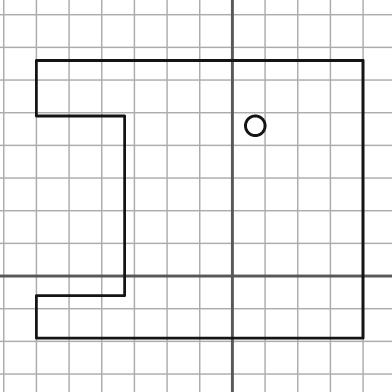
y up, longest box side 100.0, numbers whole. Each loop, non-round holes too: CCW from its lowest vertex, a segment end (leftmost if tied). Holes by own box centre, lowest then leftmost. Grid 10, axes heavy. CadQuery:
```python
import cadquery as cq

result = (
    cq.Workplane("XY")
    .moveTo(-60.0, -19.0)
    .lineTo(40.0, -19.0)
    .lineTo(40.0, 66.0)
    .lineTo(-60.0, 66.0)
    .lineTo(-60.0, 49.0)
    .lineTo(-33.0, 49.0)
    .lineTo(-33.0, -6.0)
    .lineTo(-60.0, -6.0)
    .close()
    .moveTo(7.0, 46.0)
    .circle(3.0)
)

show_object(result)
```